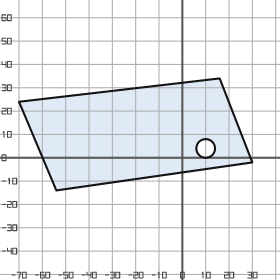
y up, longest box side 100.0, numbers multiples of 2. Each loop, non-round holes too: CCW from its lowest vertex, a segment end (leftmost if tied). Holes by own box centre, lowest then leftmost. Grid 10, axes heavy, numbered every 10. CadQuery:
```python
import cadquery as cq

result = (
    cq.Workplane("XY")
    .moveTo(-54.0, -14.0)
    .lineTo(30.0, -2.0)
    .lineTo(16.0, 34.0)
    .lineTo(-70.0, 24.0)
    .close()
    .moveTo(10.0, 4.0)
    .circle(4.0)
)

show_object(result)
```